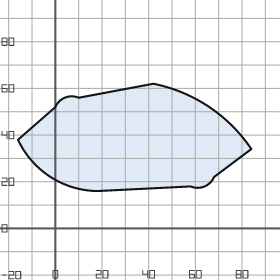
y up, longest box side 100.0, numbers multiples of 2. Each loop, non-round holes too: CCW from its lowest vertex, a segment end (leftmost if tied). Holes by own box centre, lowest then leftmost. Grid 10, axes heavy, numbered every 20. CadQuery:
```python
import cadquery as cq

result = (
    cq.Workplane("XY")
    .moveTo(18.0, 16.0)
    .lineTo(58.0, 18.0)
    .threePointArc((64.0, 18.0), (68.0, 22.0))
    .lineTo(84.0, 34.0)
    .threePointArc((66.0, 52.0), (42.0, 62.0))
    .lineTo(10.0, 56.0)
    .threePointArc((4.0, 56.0), (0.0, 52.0))
    .lineTo(-16.0, 38.0)
    .threePointArc((-2.0, 22.0), (18.0, 16.0))
    .close()
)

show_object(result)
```